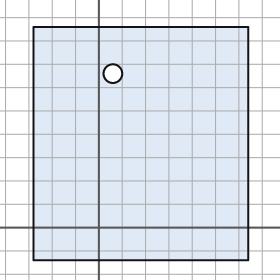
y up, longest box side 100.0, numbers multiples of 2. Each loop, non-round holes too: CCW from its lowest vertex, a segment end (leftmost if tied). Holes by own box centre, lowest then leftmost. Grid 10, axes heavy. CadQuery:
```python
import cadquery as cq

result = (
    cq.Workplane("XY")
    .moveTo(-28.0, -14.0)
    .lineTo(64.0, -14.0)
    .lineTo(64.0, 86.0)
    .lineTo(-28.0, 86.0)
    .close()
    .moveTo(6.0, 66.0)
    .circle(4.0)
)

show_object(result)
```